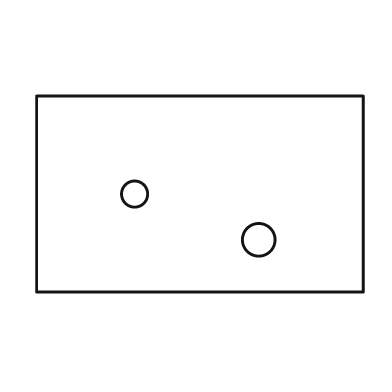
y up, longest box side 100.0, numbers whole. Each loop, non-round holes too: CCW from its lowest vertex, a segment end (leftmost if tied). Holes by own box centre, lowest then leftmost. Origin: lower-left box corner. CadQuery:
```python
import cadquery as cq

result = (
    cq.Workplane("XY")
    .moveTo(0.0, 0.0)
    .lineTo(100.0, 0.0)
    .lineTo(100.0, 60.0)
    .lineTo(0.0, 60.0)
    .close()
    .moveTo(68.0, 16.0)
    .circle(5.0)
    .moveTo(30.0, 30.0)
    .circle(4.0)
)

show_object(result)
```